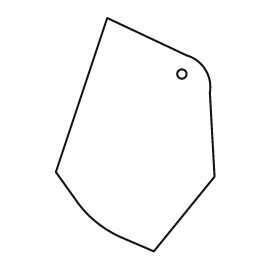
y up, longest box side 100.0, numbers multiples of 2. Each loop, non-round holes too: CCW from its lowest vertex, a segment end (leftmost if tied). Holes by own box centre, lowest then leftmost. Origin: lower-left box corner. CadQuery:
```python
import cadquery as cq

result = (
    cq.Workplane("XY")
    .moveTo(42.0, 0.0)
    .lineTo(68.0, 32.0)
    .lineTo(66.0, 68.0)
    .threePointArc((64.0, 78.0), (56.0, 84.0))
    .lineTo(22.0, 100.0)
    .lineTo(0.0, 34.0)
    .lineTo(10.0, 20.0)
    .threePointArc((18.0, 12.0), (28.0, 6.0))
    .close()
    .moveTo(54.0, 76.0)
    .circle(2.0)
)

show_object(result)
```